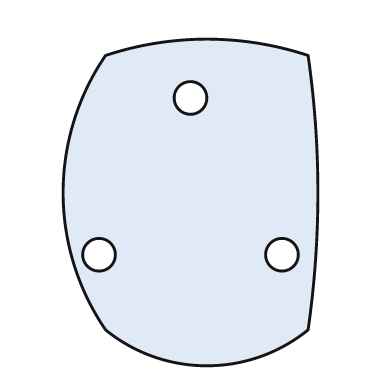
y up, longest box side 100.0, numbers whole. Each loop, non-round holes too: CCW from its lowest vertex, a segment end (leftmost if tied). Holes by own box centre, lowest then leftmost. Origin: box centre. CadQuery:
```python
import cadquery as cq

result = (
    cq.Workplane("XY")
    .moveTo(-26.0, -39.0)
    .threePointArc((5.0, -50.0), (36.0, -39.0))
    .threePointArc((39.0, 3.0), (36.0, 45.0))
    .threePointArc((5.0, 50.0), (-26.0, 45.0))
    .threePointArc((-39.0, 3.0), (-26.0, -39.0))
    .close()
    .moveTo(-28.0, -16.0)
    .circle(5.0)
    .moveTo(28.0, -16.0)
    .circle(5.0)
    .moveTo(0.0, 32.0)
    .circle(5.0)
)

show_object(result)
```